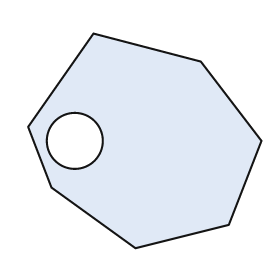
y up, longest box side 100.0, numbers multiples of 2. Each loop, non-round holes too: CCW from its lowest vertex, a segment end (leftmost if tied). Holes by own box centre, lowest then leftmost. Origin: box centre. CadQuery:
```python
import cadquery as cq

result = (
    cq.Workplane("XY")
    .moveTo(-4.0, -46.0)
    .lineTo(36.0, -36.0)
    .lineTo(50.0, 0.0)
    .lineTo(24.0, 34.0)
    .lineTo(-22.0, 46.0)
    .lineTo(-50.0, 6.0)
    .lineTo(-40.0, -20.0)
    .close()
    .moveTo(-30.0, 0.0)
    .circle(12.0)
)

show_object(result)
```